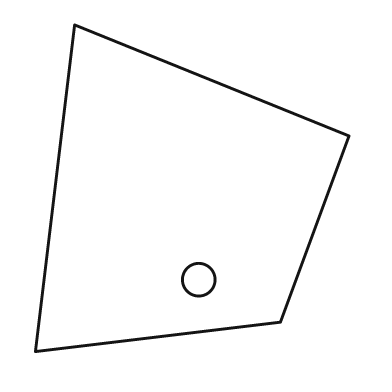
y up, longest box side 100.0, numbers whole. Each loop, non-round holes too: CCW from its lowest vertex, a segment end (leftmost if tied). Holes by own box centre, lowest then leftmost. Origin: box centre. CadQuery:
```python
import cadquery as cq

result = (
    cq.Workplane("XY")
    .moveTo(-48.0, -50.0)
    .lineTo(27.0, -41.0)
    .lineTo(48.0, 16.0)
    .lineTo(-36.0, 50.0)
    .close()
    .moveTo(2.0, -28.0)
    .circle(5.0)
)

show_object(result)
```